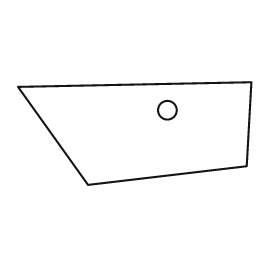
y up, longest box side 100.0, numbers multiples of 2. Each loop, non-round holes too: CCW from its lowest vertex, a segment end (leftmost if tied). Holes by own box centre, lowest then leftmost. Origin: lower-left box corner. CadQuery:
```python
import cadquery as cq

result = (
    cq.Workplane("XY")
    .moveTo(30.0, 0.0)
    .lineTo(98.0, 8.0)
    .lineTo(100.0, 44.0)
    .lineTo(0.0, 42.0)
    .close()
    .moveTo(64.0, 32.0)
    .circle(4.0)
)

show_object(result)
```